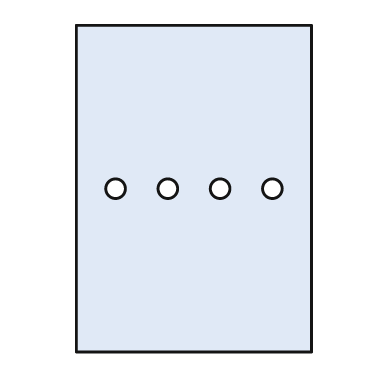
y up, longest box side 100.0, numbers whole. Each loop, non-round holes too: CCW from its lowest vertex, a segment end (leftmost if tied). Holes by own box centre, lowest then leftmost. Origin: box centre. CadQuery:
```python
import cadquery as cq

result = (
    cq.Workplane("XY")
    .moveTo(-36.0, -50.0)
    .lineTo(36.0, -50.0)
    .lineTo(36.0, 50.0)
    .lineTo(-36.0, 50.0)
    .close()
    .moveTo(-24.0, 0.0)
    .circle(3.0)
    .moveTo(-8.0, 0.0)
    .circle(3.0)
    .moveTo(8.0, 0.0)
    .circle(3.0)
    .moveTo(24.0, 0.0)
    .circle(3.0)
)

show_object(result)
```